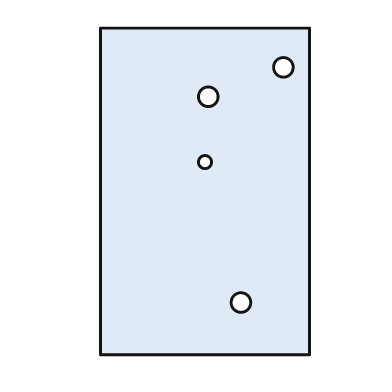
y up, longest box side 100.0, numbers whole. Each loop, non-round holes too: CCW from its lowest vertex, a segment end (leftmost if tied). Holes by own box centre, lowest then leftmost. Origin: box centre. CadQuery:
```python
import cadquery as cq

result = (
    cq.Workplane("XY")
    .moveTo(-32.0, -50.0)
    .lineTo(32.0, -50.0)
    .lineTo(32.0, 50.0)
    .lineTo(-32.0, 50.0)
    .close()
    .moveTo(11.0, -34.0)
    .circle(3.0)
    .moveTo(0.0, 9.0)
    .circle(2.0)
    .moveTo(1.0, 29.0)
    .circle(3.0)
    .moveTo(24.0, 38.0)
    .circle(3.0)
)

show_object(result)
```